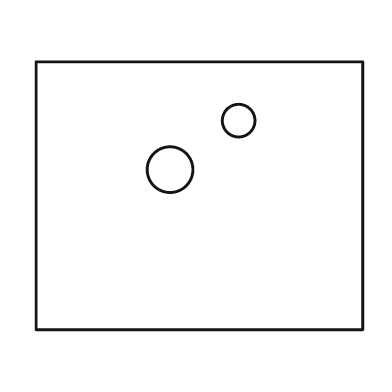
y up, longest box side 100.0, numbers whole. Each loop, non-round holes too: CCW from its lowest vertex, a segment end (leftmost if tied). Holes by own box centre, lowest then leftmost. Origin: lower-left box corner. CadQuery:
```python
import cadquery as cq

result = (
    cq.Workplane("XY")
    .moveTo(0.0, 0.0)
    .lineTo(100.0, 0.0)
    .lineTo(100.0, 82.0)
    .lineTo(0.0, 82.0)
    .close()
    .moveTo(41.0, 49.0)
    .circle(7.0)
    .moveTo(62.0, 64.0)
    .circle(5.0)
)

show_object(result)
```